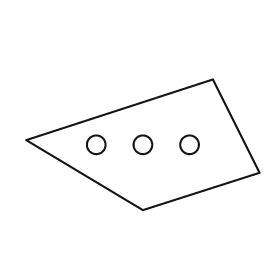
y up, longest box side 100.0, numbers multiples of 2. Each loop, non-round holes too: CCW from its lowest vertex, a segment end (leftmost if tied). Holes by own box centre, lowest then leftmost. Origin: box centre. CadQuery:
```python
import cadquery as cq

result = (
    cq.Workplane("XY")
    .moveTo(0.0, -28.0)
    .lineTo(50.0, -12.0)
    .lineTo(30.0, 28.0)
    .lineTo(-50.0, 2.0)
    .close()
    .moveTo(-20.0, 0.0)
    .circle(4.0)
    .moveTo(0.0, 0.0)
    .circle(4.0)
    .moveTo(20.0, 0.0)
    .circle(4.0)
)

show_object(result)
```